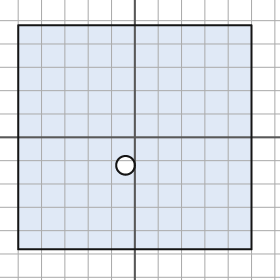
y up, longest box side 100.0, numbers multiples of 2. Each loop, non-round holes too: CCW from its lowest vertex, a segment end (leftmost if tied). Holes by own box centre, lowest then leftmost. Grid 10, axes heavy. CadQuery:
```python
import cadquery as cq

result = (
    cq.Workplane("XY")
    .moveTo(-50.0, -48.0)
    .lineTo(50.0, -48.0)
    .lineTo(50.0, 48.0)
    .lineTo(-50.0, 48.0)
    .close()
    .moveTo(-4.0, -12.0)
    .circle(4.0)
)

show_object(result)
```